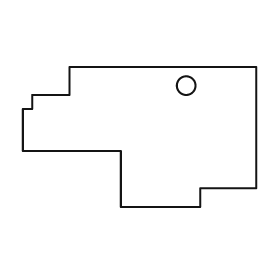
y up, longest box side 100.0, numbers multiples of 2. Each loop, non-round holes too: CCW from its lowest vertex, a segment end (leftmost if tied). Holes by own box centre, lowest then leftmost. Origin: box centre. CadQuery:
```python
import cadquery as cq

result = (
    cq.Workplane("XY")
    .moveTo(-8.0, -30.0)
    .lineTo(26.0, -30.0)
    .lineTo(26.0, -22.0)
    .lineTo(50.0, -22.0)
    .lineTo(50.0, 30.0)
    .lineTo(-30.0, 30.0)
    .lineTo(-30.0, 18.0)
    .lineTo(-46.0, 18.0)
    .lineTo(-46.0, 12.0)
    .lineTo(-50.0, 12.0)
    .lineTo(-50.0, -6.0)
    .lineTo(-8.0, -6.0)
    .close()
    .moveTo(20.0, 22.0)
    .circle(4.0)
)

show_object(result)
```